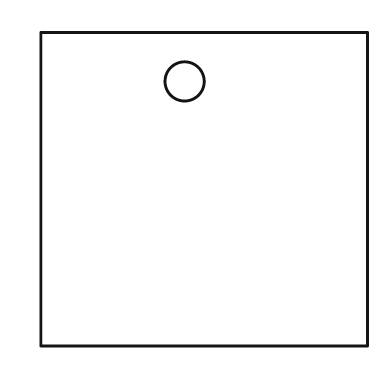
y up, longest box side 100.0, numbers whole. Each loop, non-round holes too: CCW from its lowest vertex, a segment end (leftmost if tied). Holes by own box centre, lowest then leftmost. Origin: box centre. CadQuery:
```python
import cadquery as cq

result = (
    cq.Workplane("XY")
    .moveTo(-50.0, -48.0)
    .lineTo(50.0, -48.0)
    .lineTo(50.0, 48.0)
    .lineTo(-50.0, 48.0)
    .close()
    .moveTo(-6.0, 33.0)
    .circle(6.0)
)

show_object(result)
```